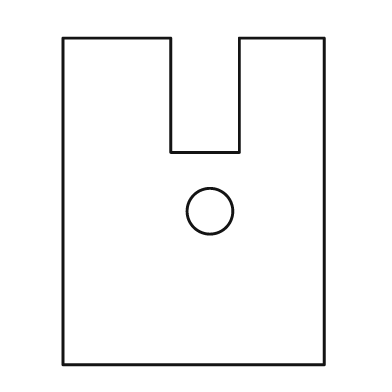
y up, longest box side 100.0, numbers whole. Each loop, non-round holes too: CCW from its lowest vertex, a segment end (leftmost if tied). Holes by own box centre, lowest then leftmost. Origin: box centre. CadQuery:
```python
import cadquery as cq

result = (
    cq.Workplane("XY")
    .moveTo(-40.0, -50.0)
    .lineTo(40.0, -50.0)
    .lineTo(40.0, 50.0)
    .lineTo(14.0, 50.0)
    .lineTo(14.0, 15.0)
    .lineTo(-7.0, 15.0)
    .lineTo(-7.0, 50.0)
    .lineTo(-40.0, 50.0)
    .close()
    .moveTo(5.0, -3.0)
    .circle(7.0)
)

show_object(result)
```